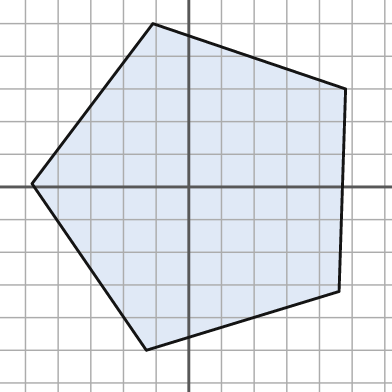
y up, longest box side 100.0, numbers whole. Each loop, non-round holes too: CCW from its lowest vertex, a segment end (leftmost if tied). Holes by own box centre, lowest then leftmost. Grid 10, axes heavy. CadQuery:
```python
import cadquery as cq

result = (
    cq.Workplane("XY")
    .moveTo(-13.0, -50.0)
    .lineTo(46.0, -32.0)
    .lineTo(48.0, 30.0)
    .lineTo(-11.0, 50.0)
    .lineTo(-48.0, 1.0)
    .close()
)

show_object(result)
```